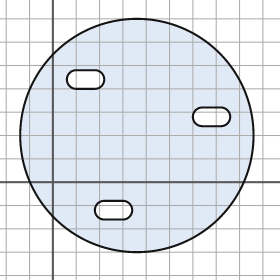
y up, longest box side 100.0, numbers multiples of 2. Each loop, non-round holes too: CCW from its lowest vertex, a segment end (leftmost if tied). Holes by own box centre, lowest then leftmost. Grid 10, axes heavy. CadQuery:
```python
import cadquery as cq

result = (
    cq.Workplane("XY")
    .moveTo(36.0, 20.0)
    .circle(50.0)
    .moveTo(22.0, -16.0)
    .lineTo(30.0, -16.0)
    .threePointArc((34.0, -12.0), (30.0, -8.0))
    .lineTo(22.0, -8.0)
    .threePointArc((18.0, -12.0), (22.0, -16.0))
    .close()
    .moveTo(64.0, 24.0)
    .lineTo(72.0, 24.0)
    .threePointArc((76.0, 28.0), (72.0, 32.0))
    .lineTo(64.0, 32.0)
    .threePointArc((60.0, 28.0), (64.0, 24.0))
    .close()
    .moveTo(10.0, 40.0)
    .lineTo(18.0, 40.0)
    .threePointArc((22.0, 44.0), (18.0, 48.0))
    .lineTo(10.0, 48.0)
    .threePointArc((6.0, 44.0), (10.0, 40.0))
    .close()
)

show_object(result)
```